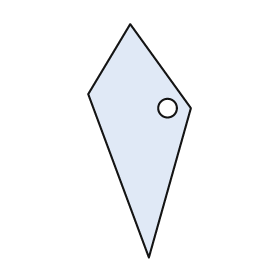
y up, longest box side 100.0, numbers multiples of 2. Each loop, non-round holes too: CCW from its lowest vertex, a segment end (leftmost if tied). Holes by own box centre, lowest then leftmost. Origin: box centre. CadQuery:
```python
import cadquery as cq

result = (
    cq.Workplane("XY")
    .moveTo(4.0, -50.0)
    .lineTo(22.0, 14.0)
    .lineTo(-4.0, 50.0)
    .lineTo(-22.0, 20.0)
    .close()
    .moveTo(12.0, 14.0)
    .circle(4.0)
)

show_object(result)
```